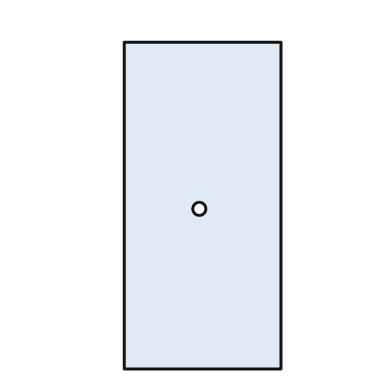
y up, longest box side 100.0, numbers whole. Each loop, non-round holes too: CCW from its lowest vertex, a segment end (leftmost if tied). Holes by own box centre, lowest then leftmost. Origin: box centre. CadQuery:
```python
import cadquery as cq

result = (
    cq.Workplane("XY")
    .moveTo(-24.0, -50.0)
    .lineTo(24.0, -50.0)
    .lineTo(24.0, 50.0)
    .lineTo(-24.0, 50.0)
    .close()
    .moveTo(-1.0, -1.0)
    .circle(2.0)
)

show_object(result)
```